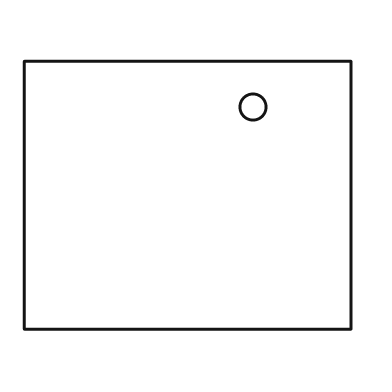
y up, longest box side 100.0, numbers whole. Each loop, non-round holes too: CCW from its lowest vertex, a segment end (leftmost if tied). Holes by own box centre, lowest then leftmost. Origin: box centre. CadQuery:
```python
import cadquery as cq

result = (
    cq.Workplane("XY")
    .moveTo(-50.0, -41.0)
    .lineTo(50.0, -41.0)
    .lineTo(50.0, 41.0)
    .lineTo(-50.0, 41.0)
    .close()
    .moveTo(20.0, 27.0)
    .circle(4.0)
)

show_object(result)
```